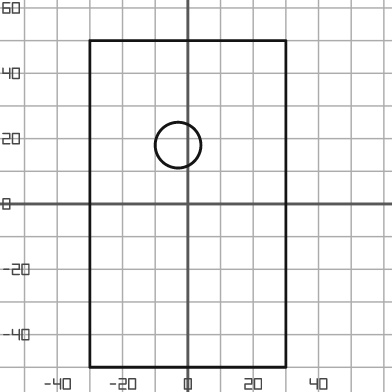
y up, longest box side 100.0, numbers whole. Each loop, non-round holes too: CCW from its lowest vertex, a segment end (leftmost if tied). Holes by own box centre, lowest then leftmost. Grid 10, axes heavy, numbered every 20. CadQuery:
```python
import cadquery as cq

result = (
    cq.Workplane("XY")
    .moveTo(-30.0, -50.0)
    .lineTo(30.0, -50.0)
    .lineTo(30.0, 50.0)
    .lineTo(-30.0, 50.0)
    .close()
    .moveTo(-3.0, 18.0)
    .circle(7.0)
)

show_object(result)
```